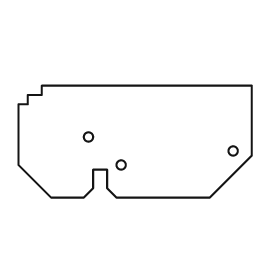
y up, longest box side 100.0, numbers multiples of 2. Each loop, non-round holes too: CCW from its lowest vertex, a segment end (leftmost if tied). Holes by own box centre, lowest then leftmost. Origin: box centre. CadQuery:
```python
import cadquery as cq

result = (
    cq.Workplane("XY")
    .moveTo(-36.0, -24.0)
    .lineTo(-22.0, -24.0)
    .lineTo(-18.0, -20.0)
    .lineTo(-18.0, -12.0)
    .lineTo(-12.0, -12.0)
    .lineTo(-12.0, -20.0)
    .lineTo(-8.0, -24.0)
    .lineTo(32.0, -24.0)
    .lineTo(50.0, -6.0)
    .lineTo(50.0, 24.0)
    .lineTo(-40.0, 24.0)
    .lineTo(-40.0, 20.0)
    .lineTo(-46.0, 20.0)
    .lineTo(-46.0, 16.0)
    .lineTo(-50.0, 16.0)
    .lineTo(-50.0, -10.0)
    .close()
    .moveTo(-6.0, -10.0)
    .circle(2.0)
    .moveTo(42.0, -4.0)
    .circle(2.0)
    .moveTo(-20.0, 2.0)
    .circle(2.0)
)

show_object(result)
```